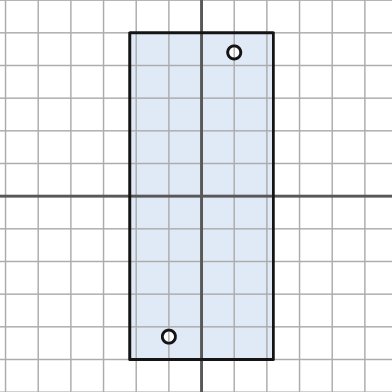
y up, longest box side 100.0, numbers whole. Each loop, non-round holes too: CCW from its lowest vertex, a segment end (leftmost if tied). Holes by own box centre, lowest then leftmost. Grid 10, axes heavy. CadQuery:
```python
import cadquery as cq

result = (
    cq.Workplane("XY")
    .moveTo(-22.0, -50.0)
    .lineTo(22.0, -50.0)
    .lineTo(22.0, 50.0)
    .lineTo(-22.0, 50.0)
    .close()
    .moveTo(-10.0, -43.0)
    .circle(2.0)
    .moveTo(10.0, 44.0)
    .circle(2.0)
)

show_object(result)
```